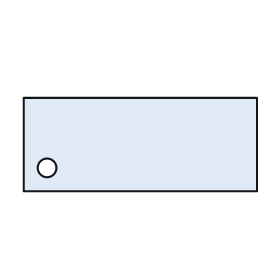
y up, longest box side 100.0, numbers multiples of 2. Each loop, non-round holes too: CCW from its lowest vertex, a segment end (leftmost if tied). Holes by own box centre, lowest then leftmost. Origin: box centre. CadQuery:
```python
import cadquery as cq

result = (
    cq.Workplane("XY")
    .moveTo(-50.0, -20.0)
    .lineTo(50.0, -20.0)
    .lineTo(50.0, 20.0)
    .lineTo(-50.0, 20.0)
    .close()
    .moveTo(-40.0, -10.0)
    .circle(4.0)
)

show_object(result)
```